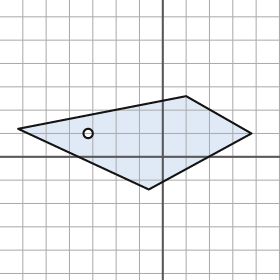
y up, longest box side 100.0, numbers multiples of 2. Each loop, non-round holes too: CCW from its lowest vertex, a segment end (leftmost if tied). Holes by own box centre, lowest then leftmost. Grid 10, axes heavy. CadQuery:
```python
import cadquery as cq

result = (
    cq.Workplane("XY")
    .moveTo(-6.0, -14.0)
    .lineTo(38.0, 10.0)
    .lineTo(10.0, 26.0)
    .lineTo(-62.0, 12.0)
    .close()
    .moveTo(-32.0, 10.0)
    .circle(2.0)
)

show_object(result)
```